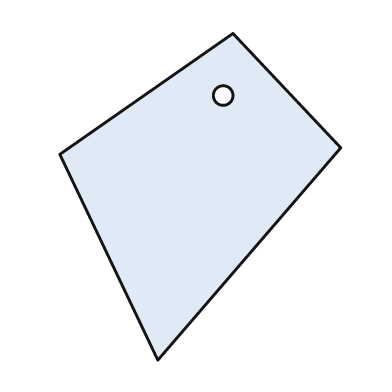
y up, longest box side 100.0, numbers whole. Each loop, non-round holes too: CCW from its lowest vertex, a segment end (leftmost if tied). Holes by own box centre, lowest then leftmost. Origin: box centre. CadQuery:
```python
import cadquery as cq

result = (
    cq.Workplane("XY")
    .moveTo(-13.0, -50.0)
    .lineTo(43.0, 15.0)
    .lineTo(10.0, 50.0)
    .lineTo(-43.0, 13.0)
    .close()
    .moveTo(7.0, 31.0)
    .circle(3.0)
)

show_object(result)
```